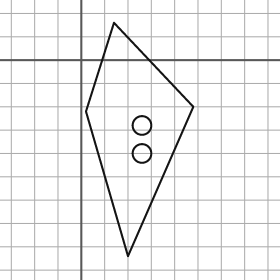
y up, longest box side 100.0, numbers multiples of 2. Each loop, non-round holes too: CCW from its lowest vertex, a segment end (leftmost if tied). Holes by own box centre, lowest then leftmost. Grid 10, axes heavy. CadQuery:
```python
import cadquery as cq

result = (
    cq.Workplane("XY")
    .moveTo(20.0, -84.0)
    .lineTo(48.0, -20.0)
    .lineTo(14.0, 16.0)
    .lineTo(2.0, -22.0)
    .close()
    .moveTo(26.0, -40.0)
    .circle(4.0)
    .moveTo(26.0, -28.0)
    .circle(4.0)
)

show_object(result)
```